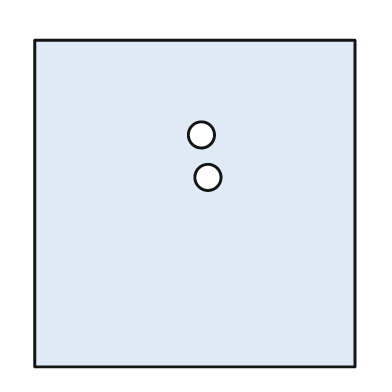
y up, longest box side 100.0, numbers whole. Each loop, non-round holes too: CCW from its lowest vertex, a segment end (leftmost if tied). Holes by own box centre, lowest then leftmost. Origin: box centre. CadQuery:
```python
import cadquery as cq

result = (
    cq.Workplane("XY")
    .moveTo(-49.0, -50.0)
    .lineTo(49.0, -50.0)
    .lineTo(49.0, 50.0)
    .lineTo(-49.0, 50.0)
    .close()
    .moveTo(4.0, 8.0)
    .circle(4.0)
    .moveTo(2.0, 21.0)
    .circle(4.0)
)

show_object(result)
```